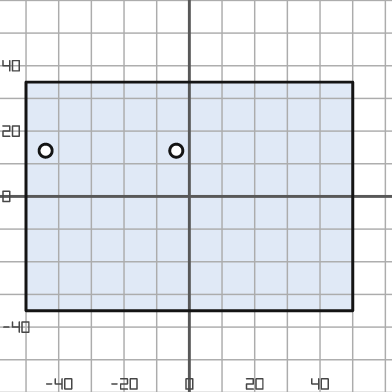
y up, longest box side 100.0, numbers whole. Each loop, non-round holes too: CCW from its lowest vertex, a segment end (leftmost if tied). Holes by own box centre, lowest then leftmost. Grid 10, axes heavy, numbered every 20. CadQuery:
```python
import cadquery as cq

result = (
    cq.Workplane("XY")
    .moveTo(-50.0, -35.0)
    .lineTo(50.0, -35.0)
    .lineTo(50.0, 35.0)
    .lineTo(-50.0, 35.0)
    .close()
    .moveTo(-44.0, 14.0)
    .circle(2.0)
    .moveTo(-4.0, 14.0)
    .circle(2.0)
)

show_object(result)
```